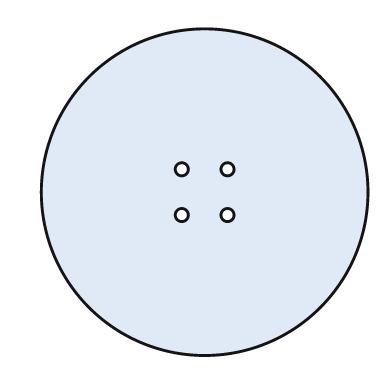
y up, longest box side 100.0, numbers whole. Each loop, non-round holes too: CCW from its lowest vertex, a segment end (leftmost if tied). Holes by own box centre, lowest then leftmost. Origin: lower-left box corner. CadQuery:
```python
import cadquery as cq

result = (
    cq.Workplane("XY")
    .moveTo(50.0, 50.0)
    .circle(50.0)
    .moveTo(43.0, 43.0)
    .circle(2.0)
    .moveTo(57.0, 43.0)
    .circle(2.0)
    .moveTo(43.0, 57.0)
    .circle(2.0)
    .moveTo(57.0, 57.0)
    .circle(2.0)
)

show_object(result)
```